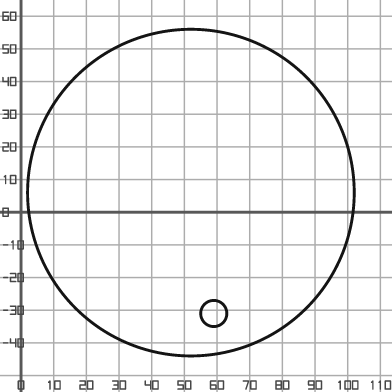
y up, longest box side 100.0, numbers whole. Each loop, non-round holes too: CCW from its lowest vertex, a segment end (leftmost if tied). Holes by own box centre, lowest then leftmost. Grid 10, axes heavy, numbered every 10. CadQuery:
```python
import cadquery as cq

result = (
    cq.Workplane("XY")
    .moveTo(52.0, 6.0)
    .circle(50.0)
    .moveTo(59.0, -31.0)
    .circle(4.0)
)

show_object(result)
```